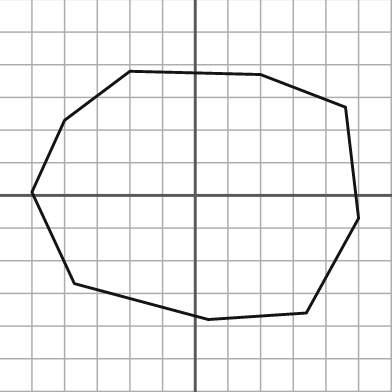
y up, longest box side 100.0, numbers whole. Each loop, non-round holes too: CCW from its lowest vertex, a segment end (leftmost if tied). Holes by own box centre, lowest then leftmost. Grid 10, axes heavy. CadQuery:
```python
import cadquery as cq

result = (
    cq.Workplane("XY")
    .moveTo(4.0, -38.0)
    .lineTo(34.0, -36.0)
    .lineTo(50.0, -7.0)
    .lineTo(46.0, 27.0)
    .lineTo(20.0, 37.0)
    .lineTo(-20.0, 38.0)
    .lineTo(-40.0, 23.0)
    .lineTo(-50.0, 1.0)
    .lineTo(-37.0, -27.0)
    .close()
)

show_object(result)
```